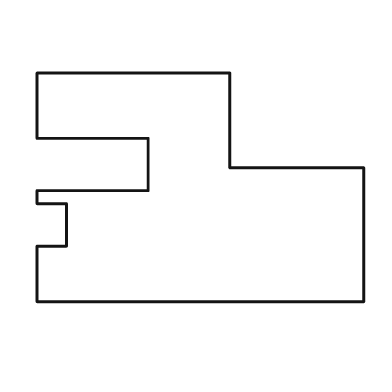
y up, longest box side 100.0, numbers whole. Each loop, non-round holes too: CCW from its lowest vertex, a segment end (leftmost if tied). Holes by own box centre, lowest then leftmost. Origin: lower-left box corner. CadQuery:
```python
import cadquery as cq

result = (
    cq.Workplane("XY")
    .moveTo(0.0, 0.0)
    .lineTo(100.0, 0.0)
    .lineTo(100.0, 41.0)
    .lineTo(59.0, 41.0)
    .lineTo(59.0, 70.0)
    .lineTo(0.0, 70.0)
    .lineTo(0.0, 50.0)
    .lineTo(34.0, 50.0)
    .lineTo(34.0, 34.0)
    .lineTo(0.0, 34.0)
    .lineTo(0.0, 30.0)
    .lineTo(9.0, 30.0)
    .lineTo(9.0, 17.0)
    .lineTo(0.0, 17.0)
    .close()
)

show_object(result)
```